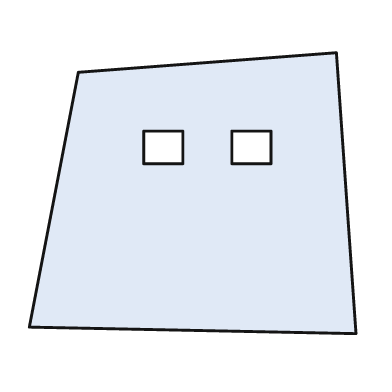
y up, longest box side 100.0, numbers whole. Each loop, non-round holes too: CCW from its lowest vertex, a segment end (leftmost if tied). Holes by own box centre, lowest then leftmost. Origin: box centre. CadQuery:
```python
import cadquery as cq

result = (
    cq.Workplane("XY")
    .moveTo(50.0, -43.0)
    .lineTo(44.0, 43.0)
    .lineTo(-35.0, 37.0)
    .lineTo(-50.0, -41.0)
    .close()
    .moveTo(-15.0, 9.0)
    .lineTo(-3.0, 9.0)
    .lineTo(-3.0, 19.0)
    .lineTo(-15.0, 19.0)
    .close()
    .moveTo(12.0, 9.0)
    .lineTo(24.0, 9.0)
    .lineTo(24.0, 19.0)
    .lineTo(12.0, 19.0)
    .close()
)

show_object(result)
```